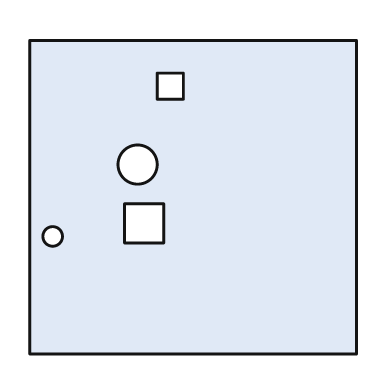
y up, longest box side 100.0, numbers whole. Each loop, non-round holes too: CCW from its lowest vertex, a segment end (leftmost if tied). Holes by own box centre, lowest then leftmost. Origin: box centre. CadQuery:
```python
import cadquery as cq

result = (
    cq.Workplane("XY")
    .moveTo(-50.0, -48.0)
    .lineTo(50.0, -48.0)
    .lineTo(50.0, 48.0)
    .lineTo(-50.0, 48.0)
    .close()
    .moveTo(-43.0, -12.0)
    .circle(3.0)
    .moveTo(-21.0, -14.0)
    .lineTo(-9.0, -14.0)
    .lineTo(-9.0, -2.0)
    .lineTo(-21.0, -2.0)
    .close()
    .moveTo(-17.0, 10.0)
    .circle(6.0)
    .moveTo(-11.0, 30.0)
    .lineTo(-3.0, 30.0)
    .lineTo(-3.0, 38.0)
    .lineTo(-11.0, 38.0)
    .close()
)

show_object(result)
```